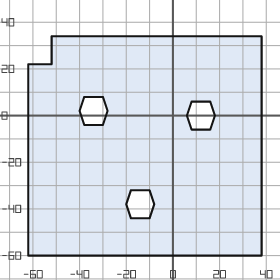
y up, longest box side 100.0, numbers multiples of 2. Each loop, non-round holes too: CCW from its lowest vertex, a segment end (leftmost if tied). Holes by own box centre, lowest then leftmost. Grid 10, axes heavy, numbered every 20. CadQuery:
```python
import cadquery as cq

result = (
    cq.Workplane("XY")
    .moveTo(-62.0, -60.0)
    .lineTo(38.0, -60.0)
    .lineTo(38.0, 34.0)
    .lineTo(-52.0, 34.0)
    .lineTo(-52.0, 22.0)
    .lineTo(-62.0, 22.0)
    .close()
    .moveTo(-18.0, -44.0)
    .lineTo(-10.0, -44.0)
    .lineTo(-8.0, -38.0)
    .lineTo(-10.0, -32.0)
    .lineTo(-18.0, -32.0)
    .lineTo(-20.0, -38.0)
    .close()
    .moveTo(8.0, -6.0)
    .lineTo(16.0, -6.0)
    .lineTo(18.0, 0.0)
    .lineTo(16.0, 6.0)
    .lineTo(8.0, 6.0)
    .lineTo(6.0, 0.0)
    .close()
    .moveTo(-38.0, -4.0)
    .lineTo(-30.0, -4.0)
    .lineTo(-28.0, 2.0)
    .lineTo(-30.0, 8.0)
    .lineTo(-38.0, 8.0)
    .lineTo(-40.0, 2.0)
    .close()
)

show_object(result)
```